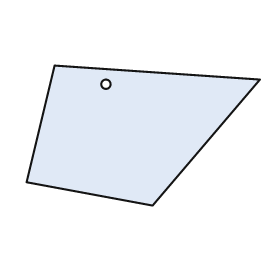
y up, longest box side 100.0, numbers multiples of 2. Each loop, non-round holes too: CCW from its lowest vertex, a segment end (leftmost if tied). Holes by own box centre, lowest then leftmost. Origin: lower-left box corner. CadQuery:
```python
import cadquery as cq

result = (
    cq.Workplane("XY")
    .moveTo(54.0, 0.0)
    .lineTo(100.0, 54.0)
    .lineTo(12.0, 60.0)
    .lineTo(0.0, 10.0)
    .close()
    .moveTo(34.0, 52.0)
    .circle(2.0)
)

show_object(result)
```